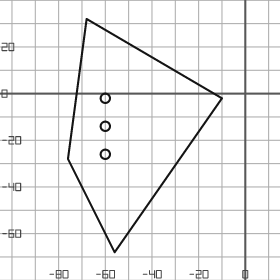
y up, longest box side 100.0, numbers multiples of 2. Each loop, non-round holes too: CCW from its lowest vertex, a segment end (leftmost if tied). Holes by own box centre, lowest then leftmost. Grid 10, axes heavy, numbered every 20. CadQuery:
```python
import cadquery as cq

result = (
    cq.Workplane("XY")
    .moveTo(-56.0, -68.0)
    .lineTo(-10.0, -2.0)
    .lineTo(-68.0, 32.0)
    .lineTo(-76.0, -28.0)
    .close()
    .moveTo(-60.0, -26.0)
    .circle(2.0)
    .moveTo(-60.0, -14.0)
    .circle(2.0)
    .moveTo(-60.0, -2.0)
    .circle(2.0)
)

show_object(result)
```